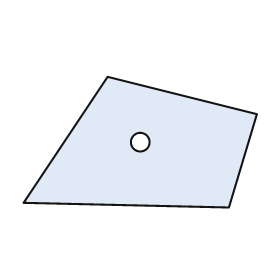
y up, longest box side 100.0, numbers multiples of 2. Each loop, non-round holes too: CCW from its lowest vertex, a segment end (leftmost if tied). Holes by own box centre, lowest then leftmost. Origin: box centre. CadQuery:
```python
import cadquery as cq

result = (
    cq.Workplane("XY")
    .moveTo(38.0, -28.0)
    .lineTo(50.0, 12.0)
    .lineTo(-14.0, 28.0)
    .lineTo(-50.0, -26.0)
    .close()
    .moveTo(0.0, 0.0)
    .circle(4.0)
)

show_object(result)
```